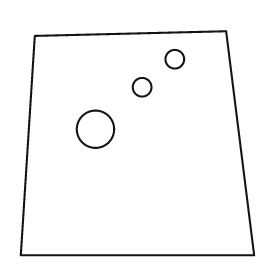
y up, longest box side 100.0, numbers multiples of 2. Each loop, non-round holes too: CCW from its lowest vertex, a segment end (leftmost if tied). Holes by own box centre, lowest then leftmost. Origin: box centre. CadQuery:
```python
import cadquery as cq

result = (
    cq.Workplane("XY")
    .moveTo(-50.0, -48.0)
    .lineTo(50.0, -48.0)
    .lineTo(38.0, 48.0)
    .lineTo(-44.0, 46.0)
    .close()
    .moveTo(-18.0, 6.0)
    .circle(8.0)
    .moveTo(2.0, 24.0)
    .circle(4.0)
    .moveTo(16.0, 36.0)
    .circle(4.0)
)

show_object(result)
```